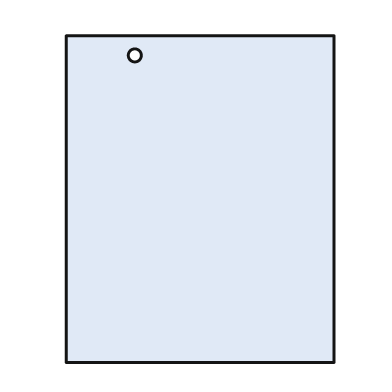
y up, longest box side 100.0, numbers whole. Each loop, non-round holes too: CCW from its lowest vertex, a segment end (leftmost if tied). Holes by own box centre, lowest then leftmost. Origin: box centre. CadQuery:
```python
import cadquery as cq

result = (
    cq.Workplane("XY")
    .moveTo(-41.0, -50.0)
    .lineTo(41.0, -50.0)
    .lineTo(41.0, 50.0)
    .lineTo(-41.0, 50.0)
    .close()
    .moveTo(-20.0, 44.0)
    .circle(2.0)
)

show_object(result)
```